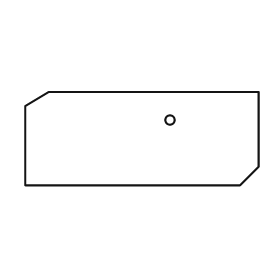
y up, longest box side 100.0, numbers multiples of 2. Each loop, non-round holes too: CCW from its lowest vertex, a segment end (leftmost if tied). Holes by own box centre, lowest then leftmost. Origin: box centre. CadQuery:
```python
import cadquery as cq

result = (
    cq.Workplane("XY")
    .moveTo(-50.0, -20.0)
    .lineTo(42.0, -20.0)
    .lineTo(50.0, -12.0)
    .lineTo(50.0, 20.0)
    .lineTo(-40.0, 20.0)
    .lineTo(-50.0, 14.0)
    .close()
    .moveTo(12.0, 8.0)
    .circle(2.0)
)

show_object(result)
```